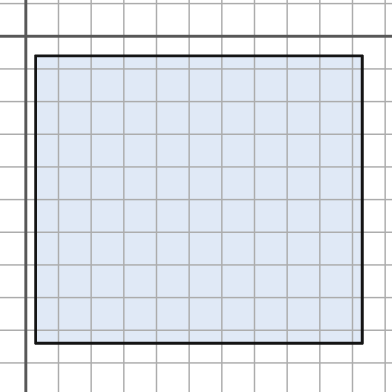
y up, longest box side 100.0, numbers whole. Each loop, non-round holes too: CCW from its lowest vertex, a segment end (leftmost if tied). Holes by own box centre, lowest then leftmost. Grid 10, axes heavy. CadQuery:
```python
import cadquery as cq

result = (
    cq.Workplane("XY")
    .moveTo(3.0, -94.0)
    .lineTo(103.0, -94.0)
    .lineTo(103.0, -6.0)
    .lineTo(3.0, -6.0)
    .close()
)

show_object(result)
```